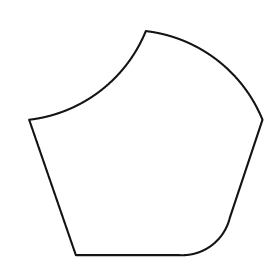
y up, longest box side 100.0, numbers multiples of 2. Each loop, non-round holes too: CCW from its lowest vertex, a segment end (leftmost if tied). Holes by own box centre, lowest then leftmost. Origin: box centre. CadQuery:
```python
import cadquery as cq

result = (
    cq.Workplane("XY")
    .moveTo(-30.0, -48.0)
    .lineTo(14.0, -48.0)
    .threePointArc((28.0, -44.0), (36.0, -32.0))
    .lineTo(50.0, 10.0)
    .threePointArc((30.0, 36.0), (0.0, 48.0))
    .threePointArc((-20.0, 22.0), (-50.0, 10.0))
    .close()
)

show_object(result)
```